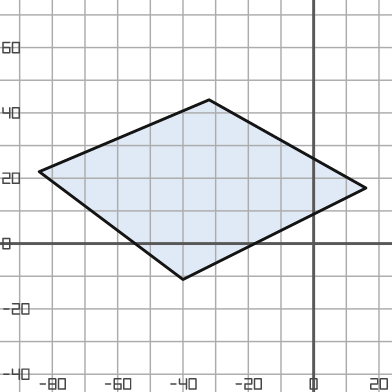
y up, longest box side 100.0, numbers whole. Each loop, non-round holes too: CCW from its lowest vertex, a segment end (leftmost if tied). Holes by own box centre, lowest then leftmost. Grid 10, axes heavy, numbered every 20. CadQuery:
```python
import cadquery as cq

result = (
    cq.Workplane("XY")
    .moveTo(-40.0, -11.0)
    .lineTo(16.0, 17.0)
    .lineTo(-32.0, 44.0)
    .lineTo(-84.0, 22.0)
    .close()
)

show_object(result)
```